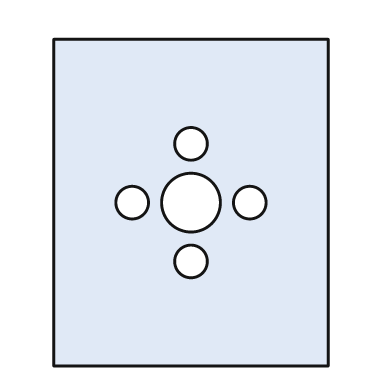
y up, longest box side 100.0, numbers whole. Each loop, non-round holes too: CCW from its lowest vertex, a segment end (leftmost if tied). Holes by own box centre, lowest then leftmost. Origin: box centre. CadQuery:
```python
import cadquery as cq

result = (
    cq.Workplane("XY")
    .moveTo(-42.0, -50.0)
    .lineTo(42.0, -50.0)
    .lineTo(42.0, 50.0)
    .lineTo(-42.0, 50.0)
    .close()
    .moveTo(0.0, -18.0)
    .circle(5.0)
    .moveTo(-18.0, 0.0)
    .circle(5.0)
    .moveTo(0.0, 0.0)
    .circle(9.0)
    .moveTo(18.0, 0.0)
    .circle(5.0)
    .moveTo(0.0, 18.0)
    .circle(5.0)
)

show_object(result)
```